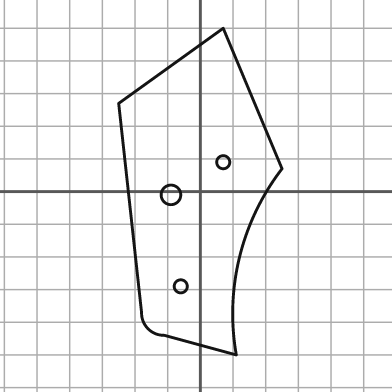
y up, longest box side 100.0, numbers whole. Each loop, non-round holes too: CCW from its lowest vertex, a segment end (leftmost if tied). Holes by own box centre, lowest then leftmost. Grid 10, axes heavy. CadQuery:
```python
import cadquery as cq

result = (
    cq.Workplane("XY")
    .moveTo(11.0, -50.0)
    .threePointArc((12.0, -20.0), (25.0, 7.0))
    .lineTo(7.0, 50.0)
    .lineTo(-25.0, 27.0)
    .lineTo(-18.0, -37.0)
    .threePointArc((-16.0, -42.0), (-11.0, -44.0))
    .close()
    .moveTo(-6.0, -29.0)
    .circle(2.0)
    .moveTo(-9.0, -1.0)
    .circle(3.0)
    .moveTo(7.0, 9.0)
    .circle(2.0)
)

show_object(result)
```